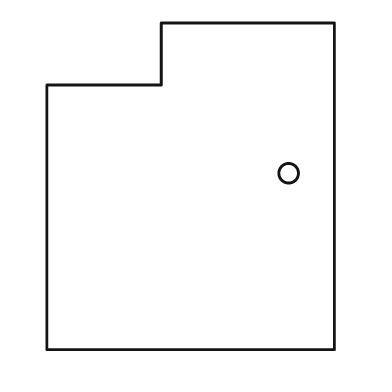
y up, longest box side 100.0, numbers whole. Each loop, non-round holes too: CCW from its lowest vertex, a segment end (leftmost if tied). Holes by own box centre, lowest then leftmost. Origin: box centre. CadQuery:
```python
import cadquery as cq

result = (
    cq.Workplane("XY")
    .moveTo(-44.0, -50.0)
    .lineTo(44.0, -50.0)
    .lineTo(44.0, 50.0)
    .lineTo(-9.0, 50.0)
    .lineTo(-9.0, 31.0)
    .lineTo(-44.0, 31.0)
    .close()
    .moveTo(30.0, 4.0)
    .circle(3.0)
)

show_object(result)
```